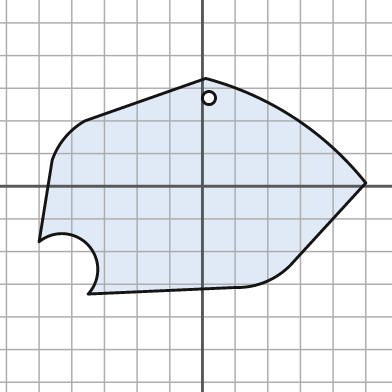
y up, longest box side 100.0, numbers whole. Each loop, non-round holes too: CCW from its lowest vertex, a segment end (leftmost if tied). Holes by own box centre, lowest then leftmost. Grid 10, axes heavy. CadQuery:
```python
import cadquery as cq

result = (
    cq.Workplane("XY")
    .moveTo(-35.0, -33.0)
    .lineTo(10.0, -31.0)
    .threePointArc((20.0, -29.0), (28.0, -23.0))
    .lineTo(50.0, 1.0)
    .threePointArc((28.0, 21.0), (1.0, 33.0))
    .lineTo(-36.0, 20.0)
    .threePointArc((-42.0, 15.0), (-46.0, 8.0))
    .lineTo(-50.0, -17.0)
    .threePointArc((-35.0, -18.0), (-35.0, -33.0))
    .close()
    .moveTo(2.0, 27.0)
    .circle(2.0)
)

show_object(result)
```